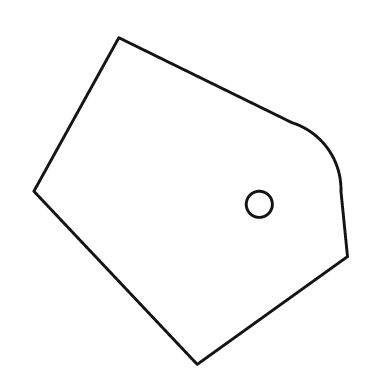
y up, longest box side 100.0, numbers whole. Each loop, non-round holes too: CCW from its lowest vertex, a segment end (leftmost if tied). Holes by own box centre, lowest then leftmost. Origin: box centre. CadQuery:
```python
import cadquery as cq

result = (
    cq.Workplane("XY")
    .moveTo(2.0, -50.0)
    .lineTo(48.0, -17.0)
    .lineTo(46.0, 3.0)
    .threePointArc((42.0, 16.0), (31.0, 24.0))
    .lineTo(-22.0, 50.0)
    .lineTo(-48.0, 3.0)
    .close()
    .moveTo(21.0, -1.0)
    .circle(4.0)
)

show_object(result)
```